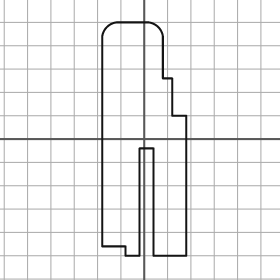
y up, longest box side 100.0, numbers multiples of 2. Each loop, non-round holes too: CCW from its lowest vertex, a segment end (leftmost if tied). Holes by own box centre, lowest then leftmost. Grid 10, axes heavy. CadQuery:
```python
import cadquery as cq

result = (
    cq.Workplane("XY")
    .moveTo(-8.0, -50.0)
    .lineTo(-2.0, -50.0)
    .lineTo(-2.0, -4.0)
    .lineTo(4.0, -4.0)
    .lineTo(4.0, -50.0)
    .lineTo(18.0, -50.0)
    .lineTo(18.0, 10.0)
    .lineTo(12.0, 10.0)
    .lineTo(12.0, 26.0)
    .lineTo(8.0, 26.0)
    .lineTo(8.0, 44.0)
    .threePointArc((6.0, 48.0), (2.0, 50.0))
    .lineTo(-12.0, 50.0)
    .threePointArc((-16.0, 48.0), (-18.0, 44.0))
    .lineTo(-18.0, -46.0)
    .lineTo(-8.0, -46.0)
    .close()
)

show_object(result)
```